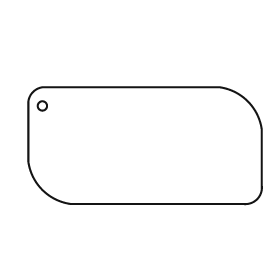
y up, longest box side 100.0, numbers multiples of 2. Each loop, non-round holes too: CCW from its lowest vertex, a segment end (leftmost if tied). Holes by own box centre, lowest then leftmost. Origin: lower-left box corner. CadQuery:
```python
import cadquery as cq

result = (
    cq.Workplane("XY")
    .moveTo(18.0, 0.0)
    .lineTo(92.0, 0.0)
    .threePointArc((98.0, 2.0), (100.0, 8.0))
    .lineTo(100.0, 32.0)
    .threePointArc((94.0, 44.0), (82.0, 50.0))
    .lineTo(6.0, 50.0)
    .threePointArc((2.0, 48.0), (0.0, 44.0))
    .lineTo(0.0, 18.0)
    .threePointArc((6.0, 6.0), (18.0, 0.0))
    .close()
    .moveTo(6.0, 42.0)
    .circle(2.0)
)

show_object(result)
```